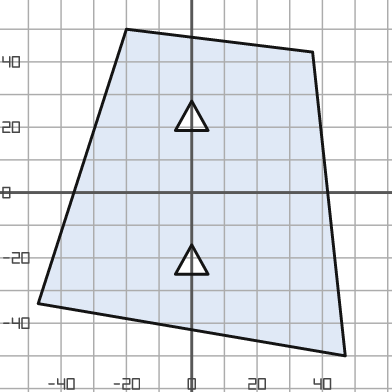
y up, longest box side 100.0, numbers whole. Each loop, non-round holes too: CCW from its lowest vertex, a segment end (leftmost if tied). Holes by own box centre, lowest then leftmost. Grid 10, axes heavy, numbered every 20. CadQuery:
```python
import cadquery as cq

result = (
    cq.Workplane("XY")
    .moveTo(47.0, -50.0)
    .lineTo(37.0, 43.0)
    .lineTo(-20.0, 50.0)
    .lineTo(-47.0, -34.0)
    .close()
    .moveTo(-5.0, -25.0)
    .lineTo(5.0, -25.0)
    .lineTo(0.0, -16.0)
    .close()
    .moveTo(-5.0, 19.0)
    .lineTo(5.0, 19.0)
    .lineTo(0.0, 28.0)
    .close()
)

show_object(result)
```